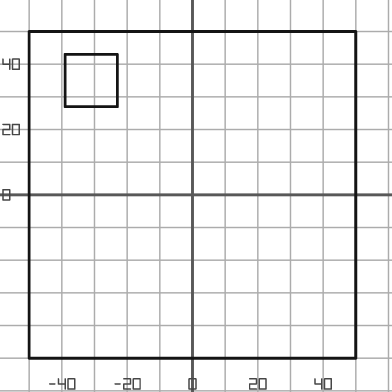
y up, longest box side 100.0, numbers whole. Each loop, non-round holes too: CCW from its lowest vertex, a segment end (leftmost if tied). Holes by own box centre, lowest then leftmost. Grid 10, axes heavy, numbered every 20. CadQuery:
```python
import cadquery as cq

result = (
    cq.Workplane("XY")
    .moveTo(-50.0, -50.0)
    .lineTo(50.0, -50.0)
    .lineTo(50.0, 50.0)
    .lineTo(-50.0, 50.0)
    .close()
    .moveTo(-39.0, 27.0)
    .lineTo(-23.0, 27.0)
    .lineTo(-23.0, 43.0)
    .lineTo(-39.0, 43.0)
    .close()
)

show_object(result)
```